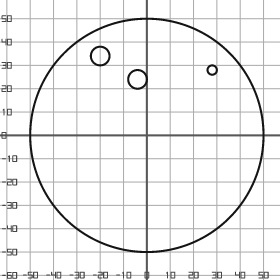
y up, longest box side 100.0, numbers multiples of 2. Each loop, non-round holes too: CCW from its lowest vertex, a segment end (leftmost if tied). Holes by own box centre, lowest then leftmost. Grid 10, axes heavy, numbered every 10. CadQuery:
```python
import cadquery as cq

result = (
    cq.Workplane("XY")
    .moveTo(0.0, 0.0)
    .circle(50.0)
    .moveTo(-4.0, 24.0)
    .circle(4.0)
    .moveTo(28.0, 28.0)
    .circle(2.0)
    .moveTo(-20.0, 34.0)
    .circle(4.0)
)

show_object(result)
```